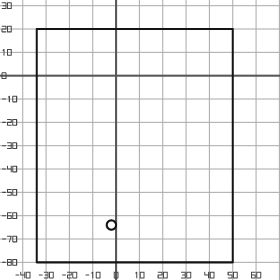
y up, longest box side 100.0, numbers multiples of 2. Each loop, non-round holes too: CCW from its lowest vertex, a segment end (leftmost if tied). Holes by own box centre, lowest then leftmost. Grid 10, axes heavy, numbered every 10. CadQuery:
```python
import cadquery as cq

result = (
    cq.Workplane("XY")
    .moveTo(-34.0, -80.0)
    .lineTo(50.0, -80.0)
    .lineTo(50.0, 20.0)
    .lineTo(-34.0, 20.0)
    .close()
    .moveTo(-2.0, -64.0)
    .circle(2.0)
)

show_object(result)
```